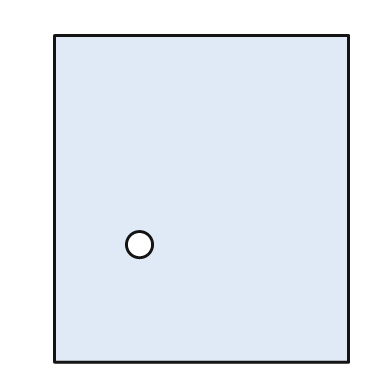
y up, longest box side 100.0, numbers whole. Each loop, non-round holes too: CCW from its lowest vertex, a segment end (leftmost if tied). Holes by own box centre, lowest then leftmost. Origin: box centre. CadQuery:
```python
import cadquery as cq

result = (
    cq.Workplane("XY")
    .moveTo(-45.0, -50.0)
    .lineTo(45.0, -50.0)
    .lineTo(45.0, 50.0)
    .lineTo(-45.0, 50.0)
    .close()
    .moveTo(-19.0, -14.0)
    .circle(4.0)
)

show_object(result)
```